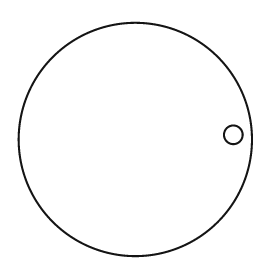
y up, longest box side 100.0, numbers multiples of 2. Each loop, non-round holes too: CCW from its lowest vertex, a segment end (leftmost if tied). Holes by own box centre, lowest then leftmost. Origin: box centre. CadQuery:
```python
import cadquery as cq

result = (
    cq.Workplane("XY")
    .moveTo(0.0, 0.0)
    .circle(50.0)
    .moveTo(42.0, 2.0)
    .circle(4.0)
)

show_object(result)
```